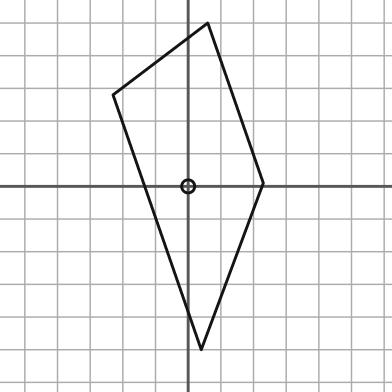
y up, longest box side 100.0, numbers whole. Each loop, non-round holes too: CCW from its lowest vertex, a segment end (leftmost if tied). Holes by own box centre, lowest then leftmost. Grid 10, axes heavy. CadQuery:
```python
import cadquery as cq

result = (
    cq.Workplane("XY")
    .moveTo(4.0, -50.0)
    .lineTo(23.0, 1.0)
    .lineTo(6.0, 50.0)
    .lineTo(-23.0, 28.0)
    .close()
    .moveTo(0.0, 0.0)
    .circle(2.0)
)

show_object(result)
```